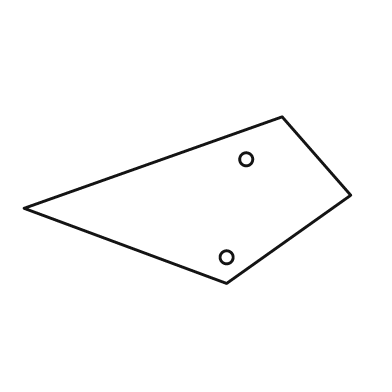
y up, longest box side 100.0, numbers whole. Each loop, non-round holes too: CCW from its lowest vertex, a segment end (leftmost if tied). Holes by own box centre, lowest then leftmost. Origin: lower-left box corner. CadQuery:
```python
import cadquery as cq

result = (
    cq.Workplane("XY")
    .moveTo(62.0, 0.0)
    .lineTo(100.0, 27.0)
    .lineTo(79.0, 51.0)
    .lineTo(0.0, 23.0)
    .close()
    .moveTo(62.0, 8.0)
    .circle(2.0)
    .moveTo(68.0, 38.0)
    .circle(2.0)
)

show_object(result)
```